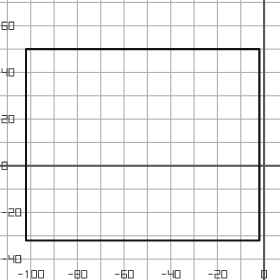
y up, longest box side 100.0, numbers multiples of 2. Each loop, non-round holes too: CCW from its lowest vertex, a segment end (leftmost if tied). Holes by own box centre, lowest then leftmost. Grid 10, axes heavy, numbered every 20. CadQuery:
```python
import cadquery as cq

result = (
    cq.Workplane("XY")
    .moveTo(-102.0, -32.0)
    .lineTo(-2.0, -32.0)
    .lineTo(-2.0, 50.0)
    .lineTo(-102.0, 50.0)
    .close()
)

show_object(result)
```